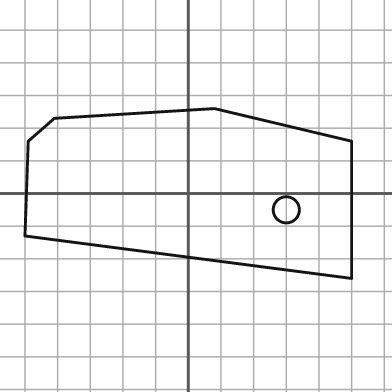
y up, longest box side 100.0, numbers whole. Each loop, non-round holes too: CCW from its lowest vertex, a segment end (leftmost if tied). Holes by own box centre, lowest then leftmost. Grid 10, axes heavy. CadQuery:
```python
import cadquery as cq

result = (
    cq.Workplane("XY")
    .moveTo(50.0, -26.0)
    .lineTo(50.0, 16.0)
    .lineTo(8.0, 26.0)
    .lineTo(-41.0, 23.0)
    .lineTo(-49.0, 16.0)
    .lineTo(-50.0, -13.0)
    .close()
    .moveTo(30.0, -5.0)
    .circle(4.0)
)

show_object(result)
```